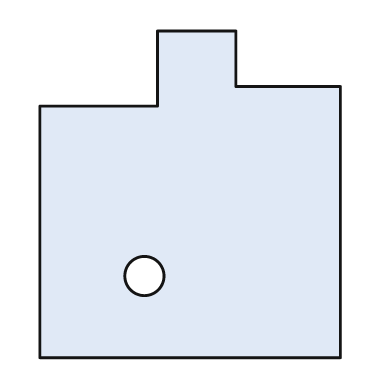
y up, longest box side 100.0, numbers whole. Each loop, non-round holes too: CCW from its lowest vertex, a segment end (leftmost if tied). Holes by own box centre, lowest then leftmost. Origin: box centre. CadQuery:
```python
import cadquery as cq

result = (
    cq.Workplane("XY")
    .moveTo(-46.0, -50.0)
    .lineTo(46.0, -50.0)
    .lineTo(46.0, 33.0)
    .lineTo(14.0, 33.0)
    .lineTo(14.0, 50.0)
    .lineTo(-10.0, 50.0)
    .lineTo(-10.0, 27.0)
    .lineTo(-46.0, 27.0)
    .close()
    .moveTo(-14.0, -25.0)
    .circle(6.0)
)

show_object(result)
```